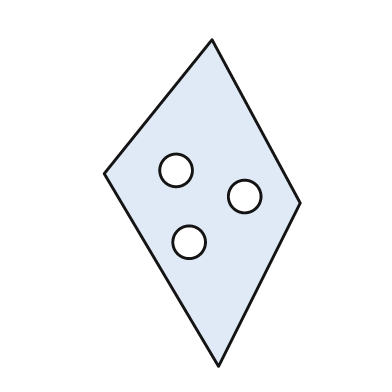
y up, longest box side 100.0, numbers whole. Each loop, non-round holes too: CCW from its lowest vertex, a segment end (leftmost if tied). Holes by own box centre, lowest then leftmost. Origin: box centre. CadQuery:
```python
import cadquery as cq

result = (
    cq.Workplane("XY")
    .moveTo(5.0, -50.0)
    .lineTo(30.0, 0.0)
    .lineTo(3.0, 50.0)
    .lineTo(-30.0, 9.0)
    .close()
    .moveTo(-4.0, -12.0)
    .circle(5.0)
    .moveTo(13.0, 2.0)
    .circle(5.0)
    .moveTo(-8.0, 10.0)
    .circle(5.0)
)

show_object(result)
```